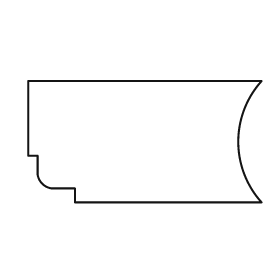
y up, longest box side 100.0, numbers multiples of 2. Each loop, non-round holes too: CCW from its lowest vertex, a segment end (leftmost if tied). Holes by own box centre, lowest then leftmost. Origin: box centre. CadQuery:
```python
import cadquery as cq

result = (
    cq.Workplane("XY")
    .moveTo(-30.0, -26.0)
    .lineTo(50.0, -26.0)
    .threePointArc((40.0, 0.0), (50.0, 26.0))
    .lineTo(-50.0, 26.0)
    .lineTo(-50.0, -6.0)
    .lineTo(-46.0, -6.0)
    .lineTo(-46.0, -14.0)
    .threePointArc((-44.0, -18.0), (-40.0, -20.0))
    .lineTo(-30.0, -20.0)
    .close()
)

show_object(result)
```